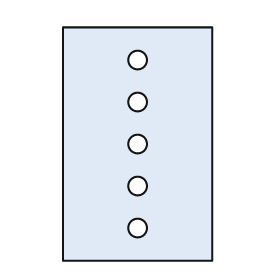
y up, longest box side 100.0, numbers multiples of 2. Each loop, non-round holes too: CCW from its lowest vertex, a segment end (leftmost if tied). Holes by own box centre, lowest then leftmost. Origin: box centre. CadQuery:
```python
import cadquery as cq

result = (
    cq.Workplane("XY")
    .moveTo(-32.0, -50.0)
    .lineTo(32.0, -50.0)
    .lineTo(32.0, 50.0)
    .lineTo(-32.0, 50.0)
    .close()
    .moveTo(0.0, -36.0)
    .circle(4.0)
    .moveTo(0.0, -18.0)
    .circle(4.0)
    .moveTo(0.0, 0.0)
    .circle(4.0)
    .moveTo(0.0, 18.0)
    .circle(4.0)
    .moveTo(0.0, 36.0)
    .circle(4.0)
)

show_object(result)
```